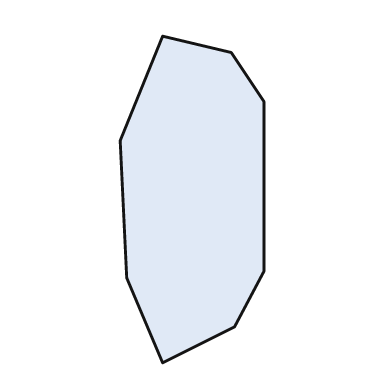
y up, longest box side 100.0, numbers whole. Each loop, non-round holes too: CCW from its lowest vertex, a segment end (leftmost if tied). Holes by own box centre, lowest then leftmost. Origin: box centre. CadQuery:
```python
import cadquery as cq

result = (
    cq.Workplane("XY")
    .moveTo(-9.0, -50.0)
    .lineTo(13.0, -39.0)
    .lineTo(22.0, -22.0)
    .lineTo(22.0, 30.0)
    .lineTo(12.0, 45.0)
    .lineTo(-9.0, 50.0)
    .lineTo(-22.0, 18.0)
    .lineTo(-20.0, -24.0)
    .close()
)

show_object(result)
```